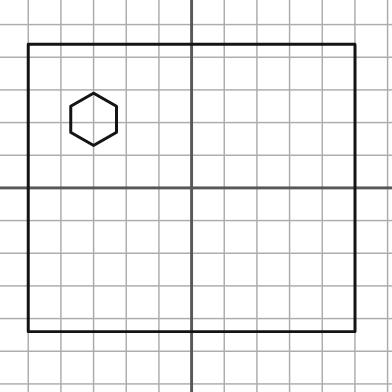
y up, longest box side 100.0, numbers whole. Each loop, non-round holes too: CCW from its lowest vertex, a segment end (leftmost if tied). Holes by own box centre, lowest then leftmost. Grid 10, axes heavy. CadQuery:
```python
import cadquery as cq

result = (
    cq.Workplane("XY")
    .moveTo(-50.0, -44.0)
    .lineTo(50.0, -44.0)
    .lineTo(50.0, 44.0)
    .lineTo(-50.0, 44.0)
    .close()
    .moveTo(-30.0, 13.0)
    .lineTo(-23.0, 17.0)
    .lineTo(-23.0, 25.0)
    .lineTo(-30.0, 29.0)
    .lineTo(-37.0, 25.0)
    .lineTo(-37.0, 17.0)
    .close()
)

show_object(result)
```